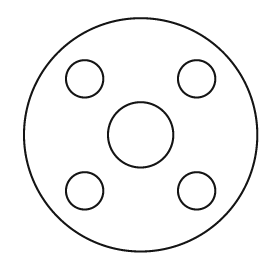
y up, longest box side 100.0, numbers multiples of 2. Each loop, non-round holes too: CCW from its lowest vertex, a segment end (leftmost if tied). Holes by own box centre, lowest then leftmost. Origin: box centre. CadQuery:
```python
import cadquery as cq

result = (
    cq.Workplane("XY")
    .moveTo(0.0, 0.0)
    .circle(50.0)
    .moveTo(-24.0, -24.0)
    .circle(8.0)
    .moveTo(24.0, -24.0)
    .circle(8.0)
    .moveTo(0.0, 0.0)
    .circle(14.0)
    .moveTo(-24.0, 24.0)
    .circle(8.0)
    .moveTo(24.0, 24.0)
    .circle(8.0)
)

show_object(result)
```